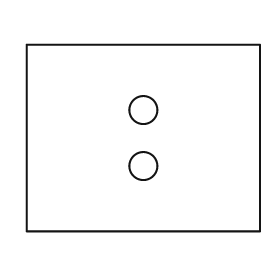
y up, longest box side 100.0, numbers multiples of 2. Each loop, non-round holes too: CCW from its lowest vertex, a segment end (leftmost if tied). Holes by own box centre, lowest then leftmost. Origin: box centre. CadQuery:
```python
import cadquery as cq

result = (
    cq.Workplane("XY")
    .moveTo(-50.0, -40.0)
    .lineTo(50.0, -40.0)
    .lineTo(50.0, 40.0)
    .lineTo(-50.0, 40.0)
    .close()
    .moveTo(0.0, -12.0)
    .circle(6.0)
    .moveTo(0.0, 12.0)
    .circle(6.0)
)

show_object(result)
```